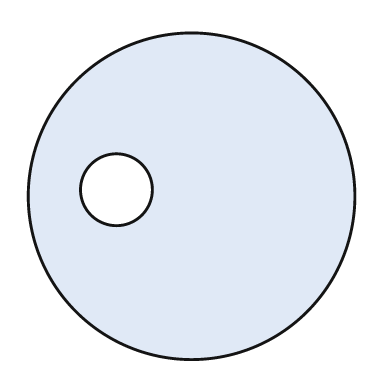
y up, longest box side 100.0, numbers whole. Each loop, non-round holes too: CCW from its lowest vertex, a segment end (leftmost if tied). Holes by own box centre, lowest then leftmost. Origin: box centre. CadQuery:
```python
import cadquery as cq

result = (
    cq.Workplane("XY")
    .moveTo(0.0, 0.0)
    .circle(50.0)
    .moveTo(-23.0, 2.0)
    .circle(11.0)
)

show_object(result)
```